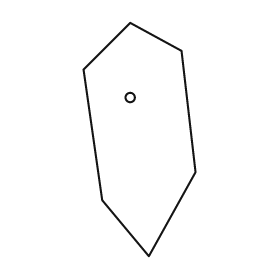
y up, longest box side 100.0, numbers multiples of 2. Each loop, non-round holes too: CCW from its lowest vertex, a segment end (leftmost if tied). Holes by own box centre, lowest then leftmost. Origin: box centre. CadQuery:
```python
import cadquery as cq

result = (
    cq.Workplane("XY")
    .moveTo(4.0, -50.0)
    .lineTo(24.0, -14.0)
    .lineTo(18.0, 38.0)
    .lineTo(-4.0, 50.0)
    .lineTo(-24.0, 30.0)
    .lineTo(-16.0, -26.0)
    .close()
    .moveTo(-4.0, 18.0)
    .circle(2.0)
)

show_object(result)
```